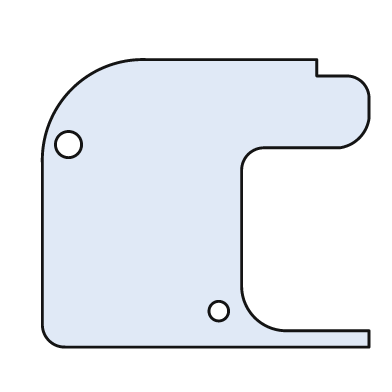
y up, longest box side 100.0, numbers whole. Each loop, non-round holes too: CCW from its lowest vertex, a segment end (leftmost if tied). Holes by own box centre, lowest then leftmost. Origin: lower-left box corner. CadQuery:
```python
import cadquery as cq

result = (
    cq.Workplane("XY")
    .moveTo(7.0, 0.0)
    .lineTo(100.0, 0.0)
    .lineTo(100.0, 5.0)
    .lineTo(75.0, 5.0)
    .threePointArc((65.0, 9.0), (61.0, 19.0))
    .lineTo(61.0, 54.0)
    .threePointArc((63.0, 59.0), (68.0, 61.0))
    .lineTo(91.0, 61.0)
    .threePointArc((97.0, 64.0), (100.0, 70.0))
    .lineTo(100.0, 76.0)
    .threePointArc((98.0, 81.0), (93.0, 83.0))
    .lineTo(84.0, 83.0)
    .lineTo(84.0, 88.0)
    .lineTo(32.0, 88.0)
    .threePointArc((9.0, 79.0), (0.0, 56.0))
    .lineTo(0.0, 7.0)
    .threePointArc((2.0, 2.0), (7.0, 0.0))
    .close()
    .moveTo(54.0, 11.0)
    .circle(3.0)
    .moveTo(8.0, 62.0)
    .circle(4.0)
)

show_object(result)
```